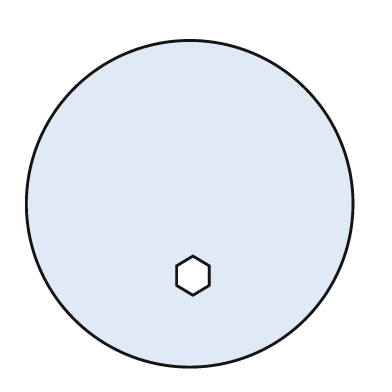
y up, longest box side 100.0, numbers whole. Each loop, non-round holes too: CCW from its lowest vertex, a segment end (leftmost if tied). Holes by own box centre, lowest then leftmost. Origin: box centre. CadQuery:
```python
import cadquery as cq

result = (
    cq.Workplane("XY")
    .moveTo(0.0, 0.0)
    .circle(50.0)
    .moveTo(1.0, -28.0)
    .lineTo(6.0, -25.0)
    .lineTo(6.0, -19.0)
    .lineTo(1.0, -16.0)
    .lineTo(-4.0, -19.0)
    .lineTo(-4.0, -25.0)
    .close()
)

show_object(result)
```